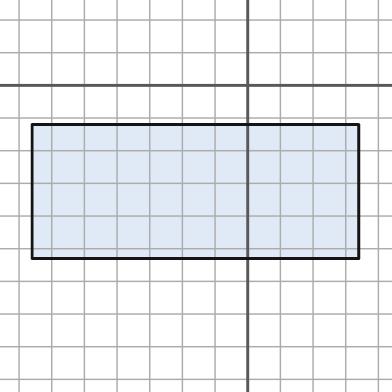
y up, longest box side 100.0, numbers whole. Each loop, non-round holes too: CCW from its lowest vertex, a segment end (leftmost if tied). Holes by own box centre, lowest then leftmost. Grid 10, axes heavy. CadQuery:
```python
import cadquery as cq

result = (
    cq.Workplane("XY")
    .moveTo(-66.0, -53.0)
    .lineTo(34.0, -53.0)
    .lineTo(34.0, -12.0)
    .lineTo(-66.0, -12.0)
    .close()
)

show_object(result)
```